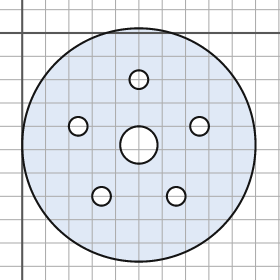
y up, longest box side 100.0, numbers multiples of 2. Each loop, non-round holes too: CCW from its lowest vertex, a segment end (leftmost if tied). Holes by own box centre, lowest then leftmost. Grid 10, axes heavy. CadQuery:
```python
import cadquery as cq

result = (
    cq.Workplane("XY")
    .moveTo(50.0, -48.0)
    .circle(50.0)
    .moveTo(34.0, -70.0)
    .circle(4.0)
    .moveTo(66.0, -70.0)
    .circle(4.0)
    .moveTo(50.0, -48.0)
    .circle(8.0)
    .moveTo(24.0, -40.0)
    .circle(4.0)
    .moveTo(76.0, -40.0)
    .circle(4.0)
    .moveTo(50.0, -20.0)
    .circle(4.0)
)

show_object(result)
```